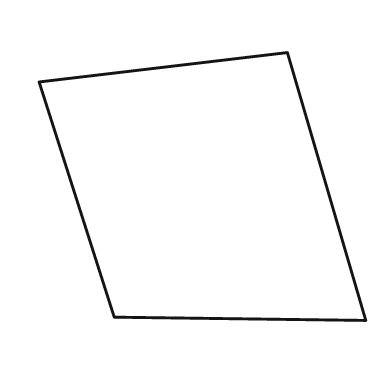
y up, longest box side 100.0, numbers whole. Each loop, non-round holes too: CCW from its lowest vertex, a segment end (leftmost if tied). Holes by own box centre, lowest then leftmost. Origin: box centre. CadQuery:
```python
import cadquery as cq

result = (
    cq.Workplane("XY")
    .moveTo(50.0, -41.0)
    .lineTo(26.0, 41.0)
    .lineTo(-50.0, 32.0)
    .lineTo(-27.0, -40.0)
    .close()
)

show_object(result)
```